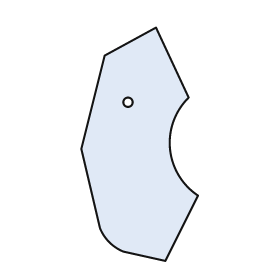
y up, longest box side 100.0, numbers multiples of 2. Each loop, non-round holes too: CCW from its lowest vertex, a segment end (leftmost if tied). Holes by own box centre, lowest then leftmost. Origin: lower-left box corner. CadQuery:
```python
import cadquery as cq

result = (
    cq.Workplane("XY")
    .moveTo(36.0, 0.0)
    .lineTo(50.0, 28.0)
    .threePointArc((38.0, 48.0), (46.0, 70.0))
    .lineTo(32.0, 100.0)
    .lineTo(10.0, 88.0)
    .lineTo(0.0, 48.0)
    .lineTo(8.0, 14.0)
    .threePointArc((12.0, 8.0), (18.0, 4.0))
    .close()
    .moveTo(20.0, 68.0)
    .circle(2.0)
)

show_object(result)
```